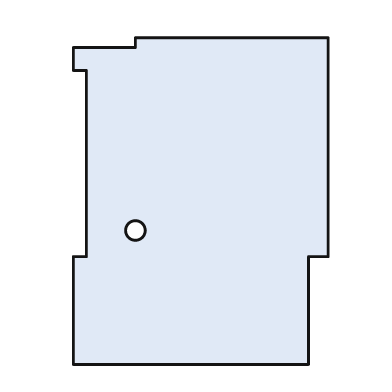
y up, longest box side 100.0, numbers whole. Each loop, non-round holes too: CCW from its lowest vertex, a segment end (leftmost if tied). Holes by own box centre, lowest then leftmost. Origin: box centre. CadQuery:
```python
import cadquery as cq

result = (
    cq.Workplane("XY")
    .moveTo(-39.0, -50.0)
    .lineTo(33.0, -50.0)
    .lineTo(33.0, -17.0)
    .lineTo(39.0, -17.0)
    .lineTo(39.0, 50.0)
    .lineTo(-20.0, 50.0)
    .lineTo(-20.0, 47.0)
    .lineTo(-39.0, 47.0)
    .lineTo(-39.0, 40.0)
    .lineTo(-35.0, 40.0)
    .lineTo(-35.0, -17.0)
    .lineTo(-39.0, -17.0)
    .close()
    .moveTo(-20.0, -9.0)
    .circle(3.0)
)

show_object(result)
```